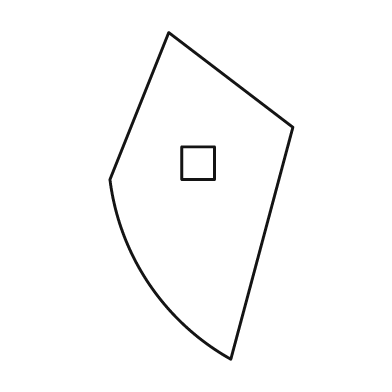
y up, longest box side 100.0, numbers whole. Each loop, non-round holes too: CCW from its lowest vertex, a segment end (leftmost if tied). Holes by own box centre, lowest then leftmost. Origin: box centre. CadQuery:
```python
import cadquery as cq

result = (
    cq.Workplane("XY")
    .moveTo(9.0, -50.0)
    .lineTo(28.0, 21.0)
    .lineTo(-10.0, 50.0)
    .lineTo(-28.0, 5.0)
    .threePointArc((-16.0, -27.0), (9.0, -50.0))
    .close()
    .moveTo(-6.0, 5.0)
    .lineTo(4.0, 5.0)
    .lineTo(4.0, 15.0)
    .lineTo(-6.0, 15.0)
    .close()
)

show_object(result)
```